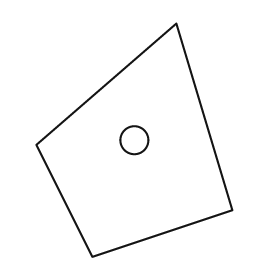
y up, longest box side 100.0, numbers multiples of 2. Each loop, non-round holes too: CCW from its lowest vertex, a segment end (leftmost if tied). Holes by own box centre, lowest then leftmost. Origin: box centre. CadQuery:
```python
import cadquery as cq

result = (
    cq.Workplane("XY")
    .moveTo(-18.0, -50.0)
    .lineTo(42.0, -30.0)
    .lineTo(18.0, 50.0)
    .lineTo(-42.0, -2.0)
    .close()
    .moveTo(0.0, 0.0)
    .circle(6.0)
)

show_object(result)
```